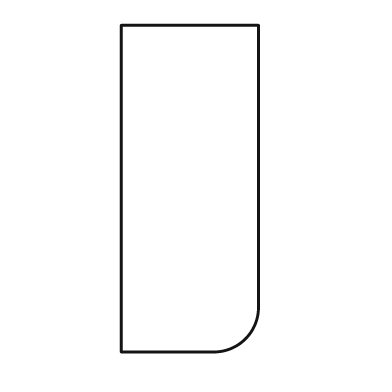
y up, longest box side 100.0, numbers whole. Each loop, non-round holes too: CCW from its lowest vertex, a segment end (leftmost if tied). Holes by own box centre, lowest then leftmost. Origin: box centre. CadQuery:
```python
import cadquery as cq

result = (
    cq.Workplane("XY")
    .moveTo(-21.0, -50.0)
    .lineTo(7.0, -50.0)
    .threePointArc((17.0, -46.0), (21.0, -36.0))
    .lineTo(21.0, 50.0)
    .lineTo(-21.0, 50.0)
    .close()
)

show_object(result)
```